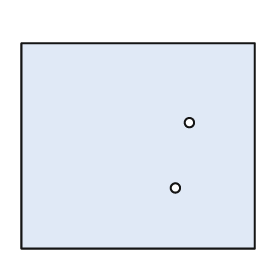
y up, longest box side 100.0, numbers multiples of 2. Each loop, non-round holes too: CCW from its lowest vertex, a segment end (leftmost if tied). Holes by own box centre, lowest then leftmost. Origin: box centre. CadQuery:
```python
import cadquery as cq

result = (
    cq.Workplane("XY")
    .moveTo(-50.0, -44.0)
    .lineTo(50.0, -44.0)
    .lineTo(50.0, 44.0)
    .lineTo(-50.0, 44.0)
    .close()
    .moveTo(16.0, -18.0)
    .circle(2.0)
    .moveTo(22.0, 10.0)
    .circle(2.0)
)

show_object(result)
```